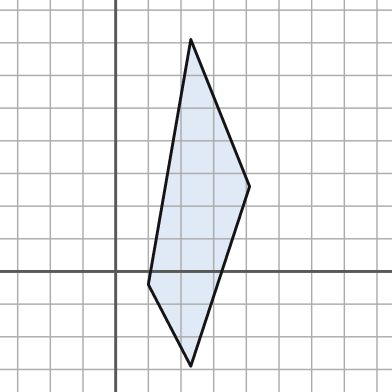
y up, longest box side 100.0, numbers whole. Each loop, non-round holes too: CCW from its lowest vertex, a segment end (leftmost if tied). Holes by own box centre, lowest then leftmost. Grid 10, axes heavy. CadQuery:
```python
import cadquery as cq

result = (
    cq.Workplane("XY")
    .moveTo(23.0, -29.0)
    .lineTo(41.0, 26.0)
    .lineTo(23.0, 71.0)
    .lineTo(10.0, -4.0)
    .close()
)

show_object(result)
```